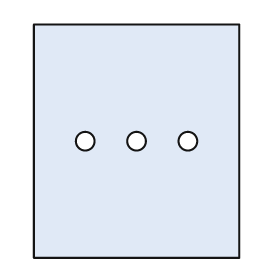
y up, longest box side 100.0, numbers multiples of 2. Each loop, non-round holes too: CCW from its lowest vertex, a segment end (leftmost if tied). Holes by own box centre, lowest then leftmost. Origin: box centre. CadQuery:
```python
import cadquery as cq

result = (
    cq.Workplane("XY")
    .moveTo(-44.0, -50.0)
    .lineTo(44.0, -50.0)
    .lineTo(44.0, 50.0)
    .lineTo(-44.0, 50.0)
    .close()
    .moveTo(-22.0, 0.0)
    .circle(4.0)
    .moveTo(0.0, 0.0)
    .circle(4.0)
    .moveTo(22.0, 0.0)
    .circle(4.0)
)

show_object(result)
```